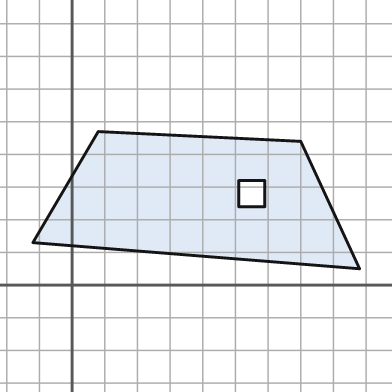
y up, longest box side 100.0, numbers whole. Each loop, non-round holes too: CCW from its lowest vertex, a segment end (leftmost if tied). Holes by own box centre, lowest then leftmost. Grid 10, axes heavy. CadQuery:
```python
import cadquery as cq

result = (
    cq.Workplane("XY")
    .moveTo(88.0, 5.0)
    .lineTo(70.0, 44.0)
    .lineTo(8.0, 47.0)
    .lineTo(-12.0, 13.0)
    .close()
    .moveTo(51.0, 24.0)
    .lineTo(59.0, 24.0)
    .lineTo(59.0, 32.0)
    .lineTo(51.0, 32.0)
    .close()
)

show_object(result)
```